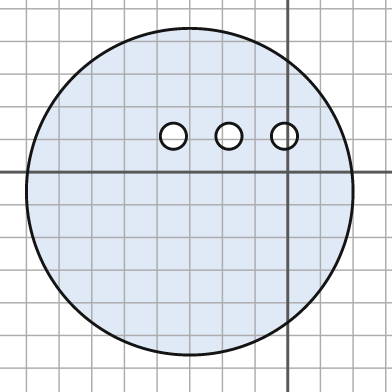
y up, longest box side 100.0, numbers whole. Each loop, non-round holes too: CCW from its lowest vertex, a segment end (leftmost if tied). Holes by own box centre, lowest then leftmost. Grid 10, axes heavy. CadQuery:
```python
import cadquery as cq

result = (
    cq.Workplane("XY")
    .moveTo(-30.0, -6.0)
    .circle(50.0)
    .moveTo(-35.0, 11.0)
    .circle(4.0)
    .moveTo(-18.0, 11.0)
    .circle(4.0)
    .moveTo(-1.0, 11.0)
    .circle(4.0)
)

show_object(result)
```